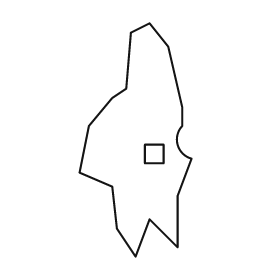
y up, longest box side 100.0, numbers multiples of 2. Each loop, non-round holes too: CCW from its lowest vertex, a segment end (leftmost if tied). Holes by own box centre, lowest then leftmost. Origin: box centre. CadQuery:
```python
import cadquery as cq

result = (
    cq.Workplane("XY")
    .moveTo(0.0, -50.0)
    .lineTo(6.0, -34.0)
    .lineTo(18.0, -46.0)
    .lineTo(18.0, -24.0)
    .lineTo(24.0, -8.0)
    .threePointArc((18.0, -2.0), (20.0, 6.0))
    .lineTo(20.0, 14.0)
    .lineTo(14.0, 40.0)
    .lineTo(6.0, 50.0)
    .lineTo(-2.0, 46.0)
    .lineTo(-4.0, 22.0)
    .lineTo(-10.0, 18.0)
    .lineTo(-20.0, 6.0)
    .lineTo(-24.0, -14.0)
    .lineTo(-10.0, -20.0)
    .lineTo(-8.0, -38.0)
    .close()
    .moveTo(4.0, -10.0)
    .lineTo(12.0, -10.0)
    .lineTo(12.0, -2.0)
    .lineTo(4.0, -2.0)
    .close()
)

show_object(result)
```